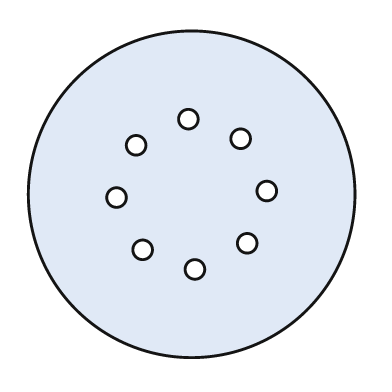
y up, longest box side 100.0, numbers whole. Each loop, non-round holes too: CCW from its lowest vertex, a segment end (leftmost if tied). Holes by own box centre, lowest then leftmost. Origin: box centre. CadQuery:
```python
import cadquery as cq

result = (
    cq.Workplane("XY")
    .moveTo(0.0, 0.0)
    .circle(50.0)
    .moveTo(1.0, -23.0)
    .circle(3.0)
    .moveTo(-15.0, -17.0)
    .circle(3.0)
    .moveTo(17.0, -15.0)
    .circle(3.0)
    .moveTo(-23.0, -1.0)
    .circle(3.0)
    .moveTo(23.0, 1.0)
    .circle(3.0)
    .moveTo(-17.0, 15.0)
    .circle(3.0)
    .moveTo(15.0, 17.0)
    .circle(3.0)
    .moveTo(-1.0, 23.0)
    .circle(3.0)
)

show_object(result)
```